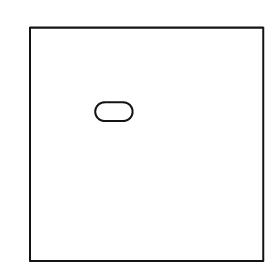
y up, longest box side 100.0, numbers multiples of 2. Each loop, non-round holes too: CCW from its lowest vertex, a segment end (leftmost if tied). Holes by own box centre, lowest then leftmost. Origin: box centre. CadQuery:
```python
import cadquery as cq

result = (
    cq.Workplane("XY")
    .moveTo(-50.0, -50.0)
    .lineTo(50.0, -50.0)
    .lineTo(50.0, 50.0)
    .lineTo(-50.0, 50.0)
    .close()
    .moveTo(-18.0, 10.0)
    .lineTo(-10.0, 10.0)
    .threePointArc((-6.0, 14.0), (-10.0, 18.0))
    .lineTo(-18.0, 18.0)
    .threePointArc((-22.0, 14.0), (-18.0, 10.0))
    .close()
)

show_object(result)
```